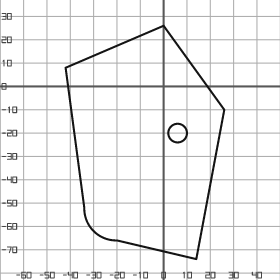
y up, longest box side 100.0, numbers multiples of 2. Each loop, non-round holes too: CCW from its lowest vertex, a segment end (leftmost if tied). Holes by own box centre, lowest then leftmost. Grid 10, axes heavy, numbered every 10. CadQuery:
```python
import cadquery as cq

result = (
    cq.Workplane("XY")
    .moveTo(14.0, -74.0)
    .lineTo(26.0, -10.0)
    .lineTo(0.0, 26.0)
    .lineTo(-42.0, 8.0)
    .lineTo(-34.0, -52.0)
    .threePointArc((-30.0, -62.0), (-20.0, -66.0))
    .close()
    .moveTo(6.0, -20.0)
    .circle(4.0)
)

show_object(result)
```